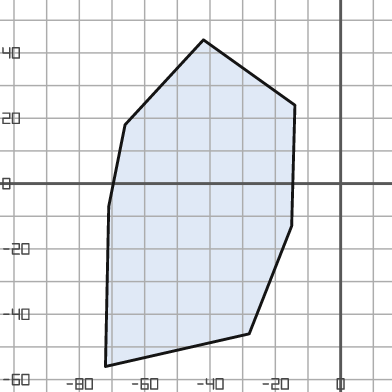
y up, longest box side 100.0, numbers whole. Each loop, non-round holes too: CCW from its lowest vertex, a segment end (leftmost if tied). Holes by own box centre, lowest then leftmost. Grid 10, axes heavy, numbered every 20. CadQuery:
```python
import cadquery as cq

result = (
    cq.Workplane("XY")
    .moveTo(-72.0, -56.0)
    .lineTo(-28.0, -46.0)
    .lineTo(-15.0, -13.0)
    .lineTo(-14.0, 24.0)
    .lineTo(-42.0, 44.0)
    .lineTo(-66.0, 18.0)
    .lineTo(-71.0, -7.0)
    .close()
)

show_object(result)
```